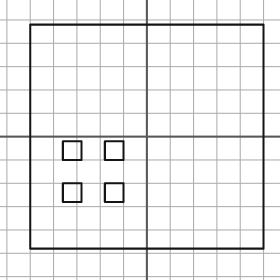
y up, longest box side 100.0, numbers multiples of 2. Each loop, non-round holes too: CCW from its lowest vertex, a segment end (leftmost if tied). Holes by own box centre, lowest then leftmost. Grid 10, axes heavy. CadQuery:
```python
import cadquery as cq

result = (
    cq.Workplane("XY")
    .moveTo(-50.0, -48.0)
    .lineTo(50.0, -48.0)
    .lineTo(50.0, 48.0)
    .lineTo(-50.0, 48.0)
    .close()
    .moveTo(-36.0, -28.0)
    .lineTo(-28.0, -28.0)
    .lineTo(-28.0, -20.0)
    .lineTo(-36.0, -20.0)
    .close()
    .moveTo(-18.0, -28.0)
    .lineTo(-10.0, -28.0)
    .lineTo(-10.0, -20.0)
    .lineTo(-18.0, -20.0)
    .close()
    .moveTo(-36.0, -10.0)
    .lineTo(-28.0, -10.0)
    .lineTo(-28.0, -2.0)
    .lineTo(-36.0, -2.0)
    .close()
    .moveTo(-18.0, -10.0)
    .lineTo(-10.0, -10.0)
    .lineTo(-10.0, -2.0)
    .lineTo(-18.0, -2.0)
    .close()
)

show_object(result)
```